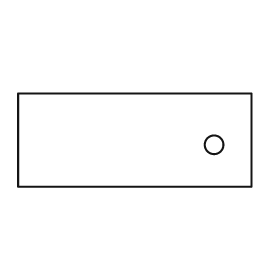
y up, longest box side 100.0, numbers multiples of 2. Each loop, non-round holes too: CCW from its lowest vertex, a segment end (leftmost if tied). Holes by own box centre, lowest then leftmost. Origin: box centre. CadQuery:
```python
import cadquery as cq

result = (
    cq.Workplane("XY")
    .moveTo(-50.0, -20.0)
    .lineTo(50.0, -20.0)
    .lineTo(50.0, 20.0)
    .lineTo(-50.0, 20.0)
    .close()
    .moveTo(34.0, -2.0)
    .circle(4.0)
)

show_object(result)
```